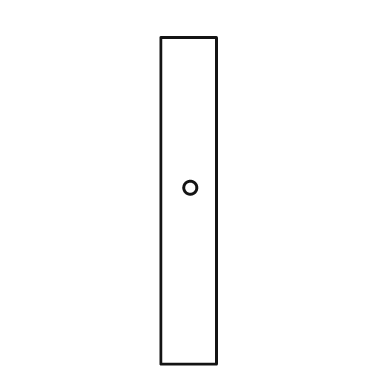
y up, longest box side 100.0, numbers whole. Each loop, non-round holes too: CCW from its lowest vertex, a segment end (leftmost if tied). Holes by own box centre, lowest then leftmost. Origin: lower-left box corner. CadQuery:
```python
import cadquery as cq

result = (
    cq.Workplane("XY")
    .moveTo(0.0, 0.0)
    .lineTo(17.0, 0.0)
    .lineTo(17.0, 100.0)
    .lineTo(0.0, 100.0)
    .close()
    .moveTo(9.0, 54.0)
    .circle(2.0)
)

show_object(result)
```